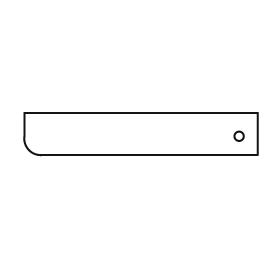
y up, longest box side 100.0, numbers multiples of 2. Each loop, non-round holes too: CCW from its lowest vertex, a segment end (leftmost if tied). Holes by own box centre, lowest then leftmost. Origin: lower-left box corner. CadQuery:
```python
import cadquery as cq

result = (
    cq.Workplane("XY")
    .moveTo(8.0, 0.0)
    .lineTo(100.0, 0.0)
    .lineTo(100.0, 18.0)
    .lineTo(0.0, 18.0)
    .lineTo(0.0, 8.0)
    .threePointArc((2.0, 2.0), (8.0, 0.0))
    .close()
    .moveTo(92.0, 8.0)
    .circle(2.0)
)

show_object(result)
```